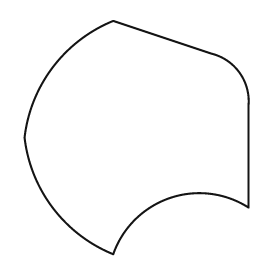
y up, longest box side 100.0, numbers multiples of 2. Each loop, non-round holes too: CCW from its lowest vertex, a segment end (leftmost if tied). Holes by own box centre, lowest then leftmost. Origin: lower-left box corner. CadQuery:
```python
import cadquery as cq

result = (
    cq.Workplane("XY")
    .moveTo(38.0, 0.0)
    .threePointArc((62.0, 24.0), (96.0, 20.0))
    .lineTo(96.0, 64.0)
    .threePointArc((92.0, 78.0), (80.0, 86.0))
    .lineTo(38.0, 100.0)
    .threePointArc((12.0, 80.0), (0.0, 50.0))
    .threePointArc((12.0, 20.0), (38.0, 0.0))
    .close()
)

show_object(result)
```